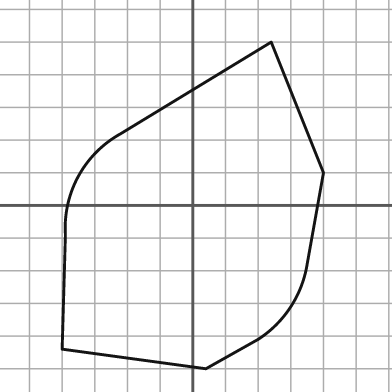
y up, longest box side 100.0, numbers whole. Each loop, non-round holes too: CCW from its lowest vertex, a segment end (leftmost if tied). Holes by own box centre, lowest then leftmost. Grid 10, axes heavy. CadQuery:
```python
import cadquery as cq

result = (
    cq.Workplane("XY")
    .moveTo(4.0, -50.0)
    .lineTo(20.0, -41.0)
    .threePointArc((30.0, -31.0), (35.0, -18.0))
    .lineTo(40.0, 10.0)
    .lineTo(24.0, 50.0)
    .lineTo(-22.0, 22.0)
    .threePointArc((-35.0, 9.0), (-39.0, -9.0))
    .lineTo(-40.0, -44.0)
    .close()
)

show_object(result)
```